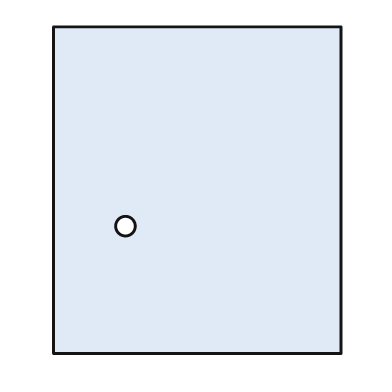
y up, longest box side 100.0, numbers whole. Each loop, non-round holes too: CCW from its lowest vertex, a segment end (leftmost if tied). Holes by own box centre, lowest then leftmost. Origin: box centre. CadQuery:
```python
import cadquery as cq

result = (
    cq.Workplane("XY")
    .moveTo(-44.0, -50.0)
    .lineTo(44.0, -50.0)
    .lineTo(44.0, 50.0)
    .lineTo(-44.0, 50.0)
    .close()
    .moveTo(-22.0, -11.0)
    .circle(3.0)
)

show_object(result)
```